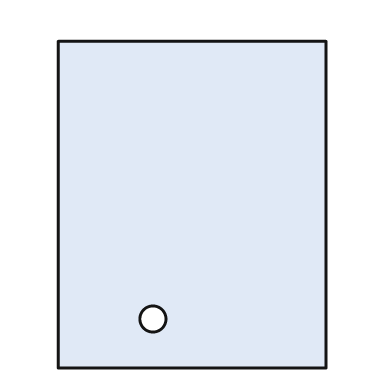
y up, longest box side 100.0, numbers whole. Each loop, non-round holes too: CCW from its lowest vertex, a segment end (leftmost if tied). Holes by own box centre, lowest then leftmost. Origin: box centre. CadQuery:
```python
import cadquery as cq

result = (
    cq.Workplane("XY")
    .moveTo(-41.0, -50.0)
    .lineTo(41.0, -50.0)
    .lineTo(41.0, 50.0)
    .lineTo(-41.0, 50.0)
    .close()
    .moveTo(-12.0, -35.0)
    .circle(4.0)
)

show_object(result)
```